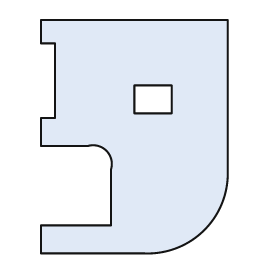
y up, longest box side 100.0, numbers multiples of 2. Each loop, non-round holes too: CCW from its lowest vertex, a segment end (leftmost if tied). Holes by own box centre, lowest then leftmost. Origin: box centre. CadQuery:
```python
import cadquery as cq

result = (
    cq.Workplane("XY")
    .moveTo(-40.0, -50.0)
    .lineTo(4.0, -50.0)
    .threePointArc((30.0, -40.0), (40.0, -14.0))
    .lineTo(40.0, 50.0)
    .lineTo(-40.0, 50.0)
    .lineTo(-40.0, 40.0)
    .lineTo(-34.0, 40.0)
    .lineTo(-34.0, 8.0)
    .lineTo(-40.0, 8.0)
    .lineTo(-40.0, -4.0)
    .lineTo(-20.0, -4.0)
    .threePointArc((-12.0, -6.0), (-10.0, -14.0))
    .lineTo(-10.0, -38.0)
    .lineTo(-40.0, -38.0)
    .close()
    .moveTo(0.0, 10.0)
    .lineTo(16.0, 10.0)
    .lineTo(16.0, 22.0)
    .lineTo(0.0, 22.0)
    .close()
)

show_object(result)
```